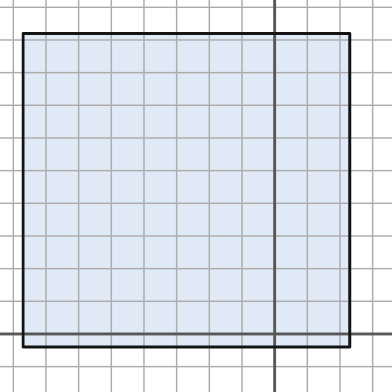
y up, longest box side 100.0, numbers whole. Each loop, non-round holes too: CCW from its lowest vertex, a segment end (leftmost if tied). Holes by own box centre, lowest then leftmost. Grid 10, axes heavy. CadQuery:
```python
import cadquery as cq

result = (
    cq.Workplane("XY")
    .moveTo(-77.0, -4.0)
    .lineTo(23.0, -4.0)
    .lineTo(23.0, 92.0)
    .lineTo(-77.0, 92.0)
    .close()
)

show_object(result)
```